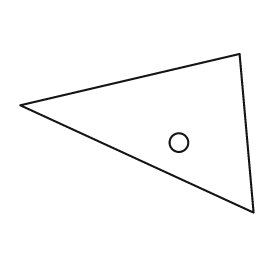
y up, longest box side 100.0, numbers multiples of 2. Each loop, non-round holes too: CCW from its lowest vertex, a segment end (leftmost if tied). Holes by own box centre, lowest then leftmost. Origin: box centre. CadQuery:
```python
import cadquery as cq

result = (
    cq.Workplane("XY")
    .moveTo(50.0, -34.0)
    .lineTo(44.0, 34.0)
    .lineTo(-50.0, 12.0)
    .close()
    .moveTo(18.0, -4.0)
    .circle(4.0)
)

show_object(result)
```